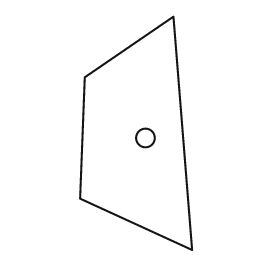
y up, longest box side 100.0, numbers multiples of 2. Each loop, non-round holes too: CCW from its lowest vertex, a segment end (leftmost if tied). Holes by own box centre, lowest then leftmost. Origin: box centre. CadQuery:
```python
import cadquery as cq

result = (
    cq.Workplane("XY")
    .moveTo(24.0, -50.0)
    .lineTo(16.0, 50.0)
    .lineTo(-22.0, 24.0)
    .lineTo(-24.0, -28.0)
    .close()
    .moveTo(4.0, -2.0)
    .circle(4.0)
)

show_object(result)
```